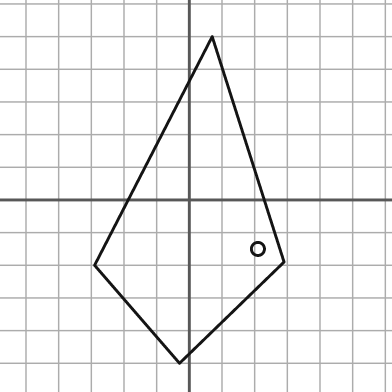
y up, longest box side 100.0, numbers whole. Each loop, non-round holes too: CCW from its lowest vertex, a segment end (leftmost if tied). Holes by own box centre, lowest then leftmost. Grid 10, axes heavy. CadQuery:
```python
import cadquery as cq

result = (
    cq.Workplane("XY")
    .moveTo(-3.0, -50.0)
    .lineTo(29.0, -19.0)
    .lineTo(7.0, 50.0)
    .lineTo(-29.0, -20.0)
    .close()
    .moveTo(21.0, -15.0)
    .circle(2.0)
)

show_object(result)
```